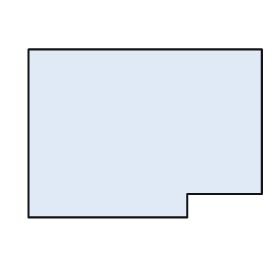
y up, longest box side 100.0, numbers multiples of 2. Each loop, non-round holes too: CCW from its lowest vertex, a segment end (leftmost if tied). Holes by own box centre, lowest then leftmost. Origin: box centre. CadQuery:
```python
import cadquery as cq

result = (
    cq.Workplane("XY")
    .moveTo(-50.0, -36.0)
    .lineTo(18.0, -36.0)
    .lineTo(18.0, -26.0)
    .lineTo(50.0, -26.0)
    .lineTo(50.0, 36.0)
    .lineTo(-50.0, 36.0)
    .close()
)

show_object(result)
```